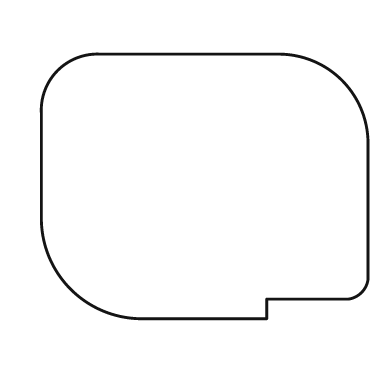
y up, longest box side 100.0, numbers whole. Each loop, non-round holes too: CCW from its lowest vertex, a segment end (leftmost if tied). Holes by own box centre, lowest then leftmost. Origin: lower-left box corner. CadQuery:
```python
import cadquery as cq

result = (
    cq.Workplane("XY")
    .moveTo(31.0, 0.0)
    .lineTo(69.0, 0.0)
    .lineTo(69.0, 6.0)
    .lineTo(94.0, 6.0)
    .threePointArc((98.0, 8.0), (100.0, 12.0))
    .lineTo(100.0, 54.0)
    .threePointArc((92.0, 73.0), (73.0, 81.0))
    .lineTo(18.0, 81.0)
    .threePointArc((5.0, 76.0), (0.0, 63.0))
    .lineTo(0.0, 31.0)
    .threePointArc((9.0, 9.0), (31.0, 0.0))
    .close()
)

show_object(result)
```